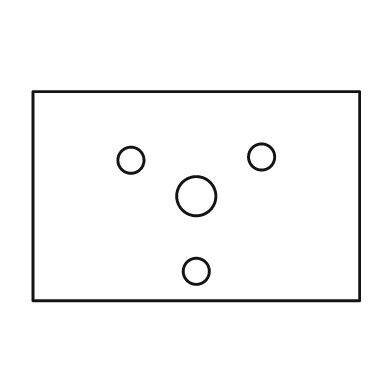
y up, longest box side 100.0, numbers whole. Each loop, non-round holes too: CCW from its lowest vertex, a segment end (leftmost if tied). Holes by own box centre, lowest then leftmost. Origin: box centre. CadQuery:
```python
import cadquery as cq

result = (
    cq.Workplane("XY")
    .moveTo(-50.0, -32.0)
    .lineTo(50.0, -32.0)
    .lineTo(50.0, 32.0)
    .lineTo(-50.0, 32.0)
    .close()
    .moveTo(0.0, -23.0)
    .circle(4.0)
    .moveTo(0.0, 0.0)
    .circle(6.0)
    .moveTo(-20.0, 11.0)
    .circle(4.0)
    .moveTo(20.0, 12.0)
    .circle(4.0)
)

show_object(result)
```